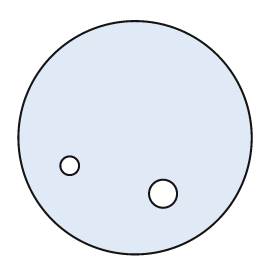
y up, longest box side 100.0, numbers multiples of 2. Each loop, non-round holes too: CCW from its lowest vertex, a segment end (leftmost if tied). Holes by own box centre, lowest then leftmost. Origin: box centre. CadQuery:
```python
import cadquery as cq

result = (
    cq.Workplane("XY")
    .moveTo(0.0, 0.0)
    .circle(50.0)
    .moveTo(12.0, -24.0)
    .circle(6.0)
    .moveTo(-28.0, -12.0)
    .circle(4.0)
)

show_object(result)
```